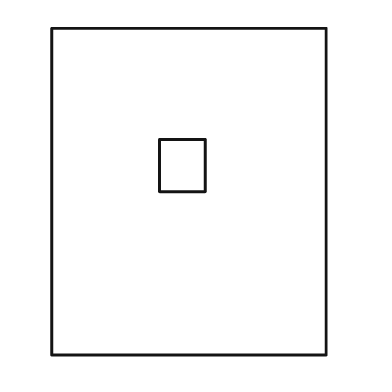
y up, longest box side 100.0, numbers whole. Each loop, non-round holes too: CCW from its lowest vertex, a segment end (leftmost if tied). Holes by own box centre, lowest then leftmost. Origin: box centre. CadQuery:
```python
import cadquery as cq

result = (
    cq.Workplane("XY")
    .moveTo(-42.0, -50.0)
    .lineTo(42.0, -50.0)
    .lineTo(42.0, 50.0)
    .lineTo(-42.0, 50.0)
    .close()
    .moveTo(-9.0, 0.0)
    .lineTo(5.0, 0.0)
    .lineTo(5.0, 16.0)
    .lineTo(-9.0, 16.0)
    .close()
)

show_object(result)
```